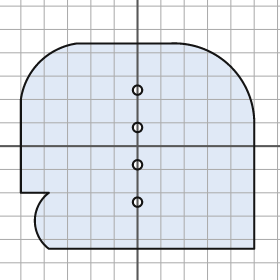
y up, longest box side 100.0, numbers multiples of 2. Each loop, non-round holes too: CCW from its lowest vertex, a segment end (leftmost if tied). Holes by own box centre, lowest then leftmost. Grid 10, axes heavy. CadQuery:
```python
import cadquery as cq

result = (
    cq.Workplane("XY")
    .moveTo(-38.0, -44.0)
    .lineTo(50.0, -44.0)
    .lineTo(50.0, 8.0)
    .threePointArc((40.0, 34.0), (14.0, 44.0))
    .lineTo(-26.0, 44.0)
    .threePointArc((-42.0, 36.0), (-50.0, 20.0))
    .lineTo(-50.0, -20.0)
    .lineTo(-38.0, -20.0)
    .threePointArc((-44.0, -32.0), (-38.0, -44.0))
    .close()
    .moveTo(0.0, -24.0)
    .circle(2.0)
    .moveTo(0.0, -8.0)
    .circle(2.0)
    .moveTo(0.0, 8.0)
    .circle(2.0)
    .moveTo(0.0, 24.0)
    .circle(2.0)
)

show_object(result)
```